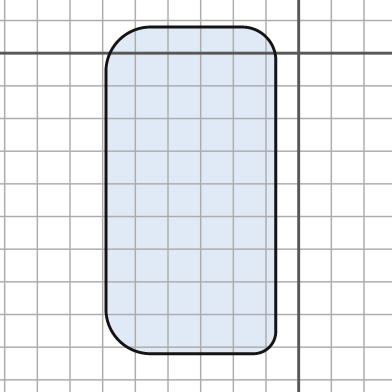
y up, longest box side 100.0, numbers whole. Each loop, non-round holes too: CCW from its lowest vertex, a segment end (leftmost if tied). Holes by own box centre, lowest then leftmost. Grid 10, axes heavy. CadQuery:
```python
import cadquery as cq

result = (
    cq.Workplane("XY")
    .moveTo(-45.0, -92.0)
    .lineTo(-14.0, -92.0)
    .threePointArc((-9.0, -90.0), (-7.0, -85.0))
    .lineTo(-7.0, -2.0)
    .threePointArc((-10.0, 5.0), (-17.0, 8.0))
    .lineTo(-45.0, 8.0)
    .threePointArc((-55.0, 4.0), (-59.0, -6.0))
    .lineTo(-59.0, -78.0)
    .threePointArc((-55.0, -88.0), (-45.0, -92.0))
    .close()
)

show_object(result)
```